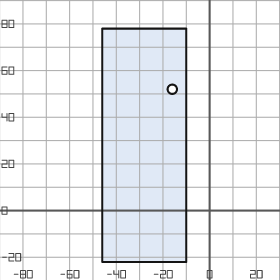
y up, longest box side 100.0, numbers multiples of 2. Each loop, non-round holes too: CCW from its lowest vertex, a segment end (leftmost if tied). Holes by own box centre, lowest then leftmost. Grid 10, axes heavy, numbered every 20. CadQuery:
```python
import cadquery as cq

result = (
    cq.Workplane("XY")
    .moveTo(-46.0, -22.0)
    .lineTo(-10.0, -22.0)
    .lineTo(-10.0, 78.0)
    .lineTo(-46.0, 78.0)
    .close()
    .moveTo(-16.0, 52.0)
    .circle(2.0)
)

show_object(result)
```